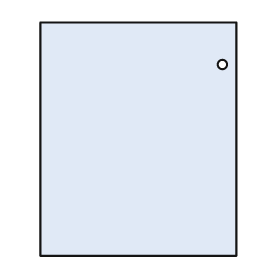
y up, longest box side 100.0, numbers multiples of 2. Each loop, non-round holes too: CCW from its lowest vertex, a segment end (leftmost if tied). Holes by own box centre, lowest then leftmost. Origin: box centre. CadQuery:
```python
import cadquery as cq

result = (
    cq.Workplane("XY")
    .moveTo(-42.0, -50.0)
    .lineTo(42.0, -50.0)
    .lineTo(42.0, 50.0)
    .lineTo(-42.0, 50.0)
    .close()
    .moveTo(36.0, 32.0)
    .circle(2.0)
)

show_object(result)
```